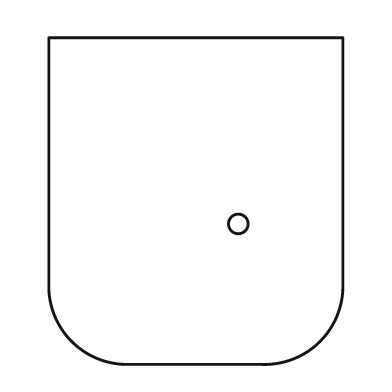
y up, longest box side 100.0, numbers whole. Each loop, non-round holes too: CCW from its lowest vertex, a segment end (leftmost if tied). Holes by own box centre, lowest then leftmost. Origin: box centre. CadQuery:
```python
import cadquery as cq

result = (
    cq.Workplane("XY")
    .moveTo(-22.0, -50.0)
    .lineTo(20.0, -50.0)
    .threePointArc((38.0, -43.0), (45.0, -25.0))
    .lineTo(45.0, 50.0)
    .lineTo(-45.0, 50.0)
    .lineTo(-45.0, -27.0)
    .threePointArc((-38.0, -43.0), (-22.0, -50.0))
    .close()
    .moveTo(13.0, -7.0)
    .circle(3.0)
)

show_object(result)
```